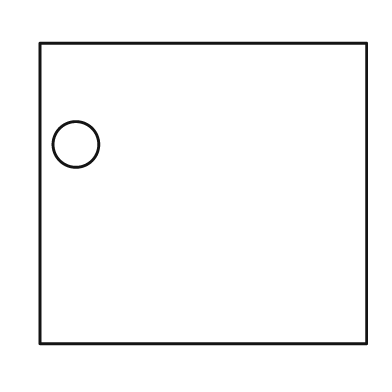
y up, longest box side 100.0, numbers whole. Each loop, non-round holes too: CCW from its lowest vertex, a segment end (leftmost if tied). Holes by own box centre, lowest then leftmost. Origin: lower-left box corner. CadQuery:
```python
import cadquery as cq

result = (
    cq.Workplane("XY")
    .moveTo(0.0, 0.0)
    .lineTo(100.0, 0.0)
    .lineTo(100.0, 92.0)
    .lineTo(0.0, 92.0)
    .close()
    .moveTo(11.0, 61.0)
    .circle(7.0)
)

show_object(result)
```